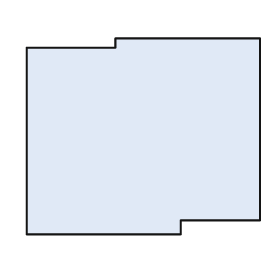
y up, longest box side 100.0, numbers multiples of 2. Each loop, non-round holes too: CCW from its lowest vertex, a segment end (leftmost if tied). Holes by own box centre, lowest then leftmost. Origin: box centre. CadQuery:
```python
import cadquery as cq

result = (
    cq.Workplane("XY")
    .moveTo(-50.0, -42.0)
    .lineTo(16.0, -42.0)
    .lineTo(16.0, -36.0)
    .lineTo(50.0, -36.0)
    .lineTo(50.0, 42.0)
    .lineTo(-12.0, 42.0)
    .lineTo(-12.0, 38.0)
    .lineTo(-50.0, 38.0)
    .close()
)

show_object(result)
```